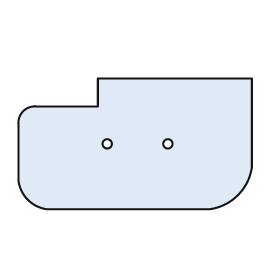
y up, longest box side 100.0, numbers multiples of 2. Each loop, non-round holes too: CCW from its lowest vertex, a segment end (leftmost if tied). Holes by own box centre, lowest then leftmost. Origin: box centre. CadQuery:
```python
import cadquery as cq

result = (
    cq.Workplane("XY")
    .moveTo(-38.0, -28.0)
    .lineTo(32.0, -28.0)
    .threePointArc((44.0, -22.0), (50.0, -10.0))
    .lineTo(50.0, 28.0)
    .lineTo(-16.0, 28.0)
    .lineTo(-16.0, 16.0)
    .lineTo(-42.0, 16.0)
    .threePointArc((-48.0, 14.0), (-50.0, 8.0))
    .lineTo(-50.0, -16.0)
    .threePointArc((-46.0, -24.0), (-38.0, -28.0))
    .close()
    .moveTo(-12.0, 0.0)
    .circle(2.0)
    .moveTo(14.0, 0.0)
    .circle(2.0)
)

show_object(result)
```